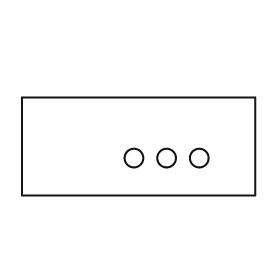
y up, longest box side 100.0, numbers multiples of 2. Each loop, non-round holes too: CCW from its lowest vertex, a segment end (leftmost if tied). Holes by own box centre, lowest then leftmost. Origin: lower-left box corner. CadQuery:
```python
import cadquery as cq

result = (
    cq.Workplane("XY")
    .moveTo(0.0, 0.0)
    .lineTo(100.0, 0.0)
    .lineTo(100.0, 42.0)
    .lineTo(0.0, 42.0)
    .close()
    .moveTo(48.0, 16.0)
    .circle(4.0)
    .moveTo(62.0, 16.0)
    .circle(4.0)
    .moveTo(76.0, 16.0)
    .circle(4.0)
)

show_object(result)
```